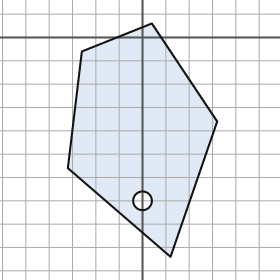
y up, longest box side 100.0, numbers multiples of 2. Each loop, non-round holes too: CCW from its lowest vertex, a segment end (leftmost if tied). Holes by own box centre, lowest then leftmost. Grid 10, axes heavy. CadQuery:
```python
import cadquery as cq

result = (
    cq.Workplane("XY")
    .moveTo(12.0, -94.0)
    .lineTo(32.0, -36.0)
    .lineTo(4.0, 6.0)
    .lineTo(-26.0, -6.0)
    .lineTo(-32.0, -56.0)
    .close()
    .moveTo(0.0, -70.0)
    .circle(4.0)
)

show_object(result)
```